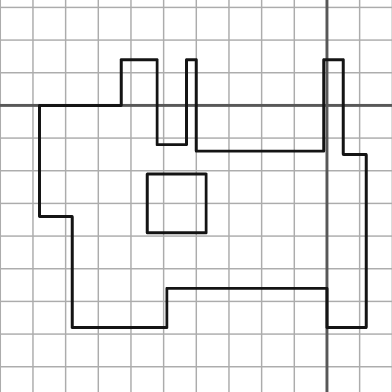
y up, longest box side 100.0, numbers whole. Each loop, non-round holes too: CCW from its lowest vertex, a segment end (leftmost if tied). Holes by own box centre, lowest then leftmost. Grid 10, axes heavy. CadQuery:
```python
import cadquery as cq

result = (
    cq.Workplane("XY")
    .moveTo(-78.0, -68.0)
    .lineTo(-49.0, -68.0)
    .lineTo(-49.0, -56.0)
    .lineTo(0.0, -56.0)
    .lineTo(0.0, -68.0)
    .lineTo(12.0, -68.0)
    .lineTo(12.0, -15.0)
    .lineTo(5.0, -15.0)
    .lineTo(5.0, 14.0)
    .lineTo(-1.0, 14.0)
    .lineTo(-1.0, -14.0)
    .lineTo(-40.0, -14.0)
    .lineTo(-40.0, 14.0)
    .lineTo(-43.0, 14.0)
    .lineTo(-43.0, -12.0)
    .lineTo(-52.0, -12.0)
    .lineTo(-52.0, 14.0)
    .lineTo(-63.0, 14.0)
    .lineTo(-63.0, 0.0)
    .lineTo(-88.0, 0.0)
    .lineTo(-88.0, -34.0)
    .lineTo(-78.0, -34.0)
    .close()
    .moveTo(-55.0, -39.0)
    .lineTo(-37.0, -39.0)
    .lineTo(-37.0, -21.0)
    .lineTo(-55.0, -21.0)
    .close()
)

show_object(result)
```